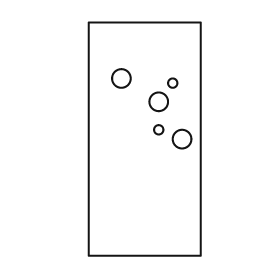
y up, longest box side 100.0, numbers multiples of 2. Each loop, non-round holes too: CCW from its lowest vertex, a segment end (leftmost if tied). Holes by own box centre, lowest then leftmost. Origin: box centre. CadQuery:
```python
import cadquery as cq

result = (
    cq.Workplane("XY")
    .moveTo(-24.0, -50.0)
    .lineTo(24.0, -50.0)
    .lineTo(24.0, 50.0)
    .lineTo(-24.0, 50.0)
    .close()
    .moveTo(16.0, 0.0)
    .circle(4.0)
    .moveTo(6.0, 4.0)
    .circle(2.0)
    .moveTo(6.0, 16.0)
    .circle(4.0)
    .moveTo(12.0, 24.0)
    .circle(2.0)
    .moveTo(-10.0, 26.0)
    .circle(4.0)
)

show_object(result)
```